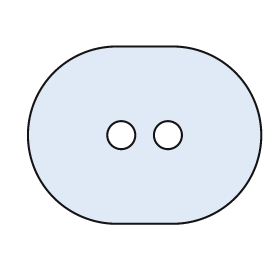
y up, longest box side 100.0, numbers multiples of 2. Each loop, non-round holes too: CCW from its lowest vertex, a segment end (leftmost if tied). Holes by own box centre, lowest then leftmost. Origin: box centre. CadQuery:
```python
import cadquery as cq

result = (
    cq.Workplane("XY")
    .moveTo(-12.0, -38.0)
    .lineTo(12.0, -38.0)
    .threePointArc((50.0, 0.0), (12.0, 38.0))
    .lineTo(-12.0, 38.0)
    .threePointArc((-50.0, 0.0), (-12.0, -38.0))
    .close()
    .moveTo(-10.0, 0.0)
    .circle(6.0)
    .moveTo(10.0, 0.0)
    .circle(6.0)
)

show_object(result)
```